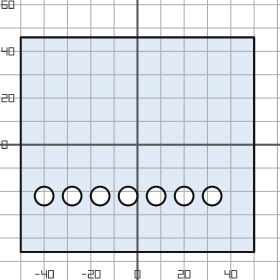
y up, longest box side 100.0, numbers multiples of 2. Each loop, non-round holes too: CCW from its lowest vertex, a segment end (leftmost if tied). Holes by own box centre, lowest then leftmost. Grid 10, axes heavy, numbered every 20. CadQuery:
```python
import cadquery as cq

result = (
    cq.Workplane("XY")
    .moveTo(-50.0, -46.0)
    .lineTo(50.0, -46.0)
    .lineTo(50.0, 46.0)
    .lineTo(-50.0, 46.0)
    .close()
    .moveTo(-40.0, -22.0)
    .circle(4.0)
    .moveTo(-28.0, -22.0)
    .circle(4.0)
    .moveTo(-16.0, -22.0)
    .circle(4.0)
    .moveTo(-4.0, -22.0)
    .circle(4.0)
    .moveTo(8.0, -22.0)
    .circle(4.0)
    .moveTo(20.0, -22.0)
    .circle(4.0)
    .moveTo(32.0, -22.0)
    .circle(4.0)
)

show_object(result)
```